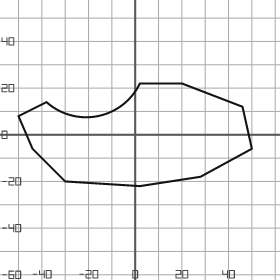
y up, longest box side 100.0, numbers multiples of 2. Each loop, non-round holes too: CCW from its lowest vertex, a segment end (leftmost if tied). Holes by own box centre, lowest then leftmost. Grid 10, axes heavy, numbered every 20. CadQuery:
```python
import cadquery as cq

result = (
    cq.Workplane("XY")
    .moveTo(2.0, -22.0)
    .lineTo(28.0, -18.0)
    .lineTo(50.0, -6.0)
    .lineTo(46.0, 12.0)
    .lineTo(20.0, 22.0)
    .lineTo(2.0, 22.0)
    .threePointArc((-16.0, 8.0), (-38.0, 14.0))
    .lineTo(-50.0, 8.0)
    .lineTo(-44.0, -6.0)
    .lineTo(-30.0, -20.0)
    .close()
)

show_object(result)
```